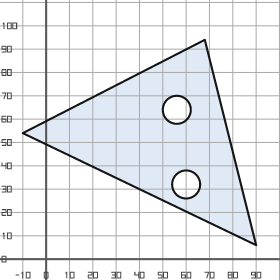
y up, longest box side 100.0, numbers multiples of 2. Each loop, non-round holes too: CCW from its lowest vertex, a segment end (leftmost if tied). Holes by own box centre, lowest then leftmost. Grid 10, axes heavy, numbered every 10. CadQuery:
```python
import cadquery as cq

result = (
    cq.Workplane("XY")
    .moveTo(90.0, 6.0)
    .lineTo(68.0, 94.0)
    .lineTo(-10.0, 54.0)
    .close()
    .moveTo(60.0, 32.0)
    .circle(6.0)
    .moveTo(56.0, 64.0)
    .circle(6.0)
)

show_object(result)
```